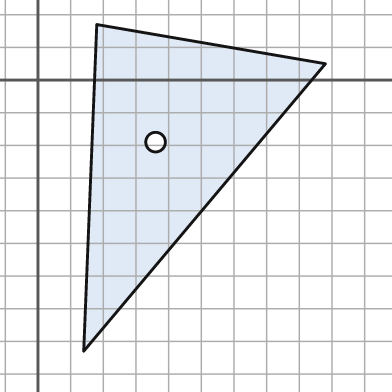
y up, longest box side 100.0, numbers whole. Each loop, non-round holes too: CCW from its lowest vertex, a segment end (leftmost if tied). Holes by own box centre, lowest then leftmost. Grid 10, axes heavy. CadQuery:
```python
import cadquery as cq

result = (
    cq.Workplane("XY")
    .moveTo(14.0, -83.0)
    .lineTo(88.0, 5.0)
    .lineTo(18.0, 17.0)
    .close()
    .moveTo(36.0, -19.0)
    .circle(3.0)
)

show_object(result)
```